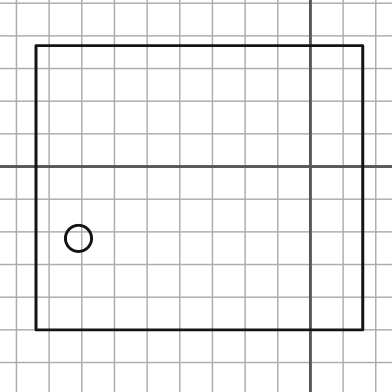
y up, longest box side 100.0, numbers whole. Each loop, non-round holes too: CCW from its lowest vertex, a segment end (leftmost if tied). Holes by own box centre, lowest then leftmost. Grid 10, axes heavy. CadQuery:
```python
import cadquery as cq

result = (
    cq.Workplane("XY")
    .moveTo(-84.0, -50.0)
    .lineTo(16.0, -50.0)
    .lineTo(16.0, 37.0)
    .lineTo(-84.0, 37.0)
    .close()
    .moveTo(-71.0, -22.0)
    .circle(4.0)
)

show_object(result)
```